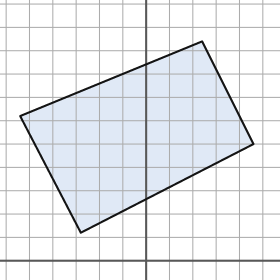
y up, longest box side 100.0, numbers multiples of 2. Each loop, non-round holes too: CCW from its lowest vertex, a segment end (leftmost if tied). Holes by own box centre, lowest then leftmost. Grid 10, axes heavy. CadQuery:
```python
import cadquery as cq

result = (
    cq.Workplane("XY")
    .moveTo(-28.0, 12.0)
    .lineTo(46.0, 50.0)
    .lineTo(24.0, 94.0)
    .lineTo(-54.0, 62.0)
    .close()
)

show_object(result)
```